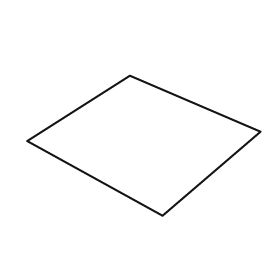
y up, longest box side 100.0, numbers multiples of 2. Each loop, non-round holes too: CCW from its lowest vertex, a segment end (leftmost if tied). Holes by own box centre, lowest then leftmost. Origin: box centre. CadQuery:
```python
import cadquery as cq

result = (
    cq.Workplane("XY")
    .moveTo(8.0, -30.0)
    .lineTo(50.0, 6.0)
    .lineTo(-6.0, 30.0)
    .lineTo(-50.0, 2.0)
    .close()
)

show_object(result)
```